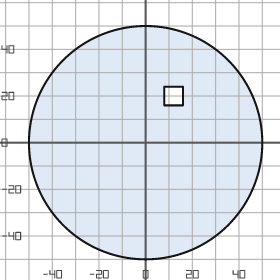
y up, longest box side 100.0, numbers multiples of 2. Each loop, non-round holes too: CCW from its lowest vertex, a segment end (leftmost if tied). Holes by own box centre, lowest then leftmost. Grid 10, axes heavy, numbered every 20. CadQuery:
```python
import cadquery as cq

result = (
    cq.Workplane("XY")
    .moveTo(0.0, 0.0)
    .circle(50.0)
    .moveTo(8.0, 16.0)
    .lineTo(16.0, 16.0)
    .lineTo(16.0, 24.0)
    .lineTo(8.0, 24.0)
    .close()
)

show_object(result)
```